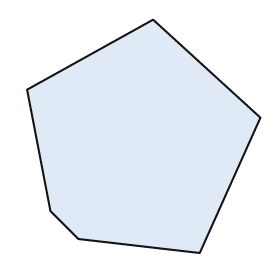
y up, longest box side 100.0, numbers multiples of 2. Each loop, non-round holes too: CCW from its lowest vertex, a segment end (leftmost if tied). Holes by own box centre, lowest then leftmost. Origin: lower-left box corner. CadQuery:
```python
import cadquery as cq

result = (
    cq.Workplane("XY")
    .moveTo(74.0, 0.0)
    .lineTo(100.0, 58.0)
    .lineTo(54.0, 100.0)
    .lineTo(0.0, 70.0)
    .lineTo(10.0, 18.0)
    .lineTo(22.0, 6.0)
    .close()
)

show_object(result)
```